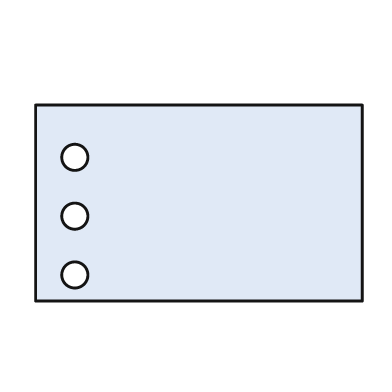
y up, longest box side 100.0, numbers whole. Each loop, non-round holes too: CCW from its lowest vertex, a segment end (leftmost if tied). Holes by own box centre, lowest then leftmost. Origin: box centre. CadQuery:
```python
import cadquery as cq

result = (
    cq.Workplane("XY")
    .moveTo(-50.0, -30.0)
    .lineTo(50.0, -30.0)
    .lineTo(50.0, 30.0)
    .lineTo(-50.0, 30.0)
    .close()
    .moveTo(-38.0, -22.0)
    .circle(4.0)
    .moveTo(-38.0, -4.0)
    .circle(4.0)
    .moveTo(-38.0, 14.0)
    .circle(4.0)
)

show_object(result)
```